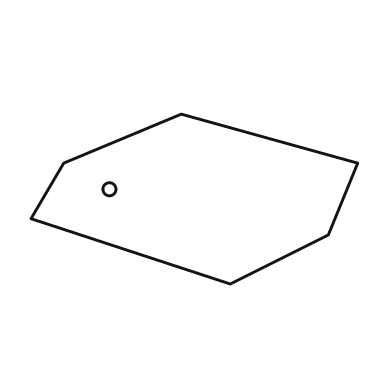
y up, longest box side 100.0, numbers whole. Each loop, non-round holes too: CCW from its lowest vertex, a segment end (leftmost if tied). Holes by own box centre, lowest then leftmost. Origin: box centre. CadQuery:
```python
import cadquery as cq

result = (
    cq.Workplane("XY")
    .moveTo(11.0, -26.0)
    .lineTo(41.0, -11.0)
    .lineTo(50.0, 11.0)
    .lineTo(-4.0, 26.0)
    .lineTo(-40.0, 11.0)
    .lineTo(-50.0, -6.0)
    .close()
    .moveTo(-26.0, 3.0)
    .circle(2.0)
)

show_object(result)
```